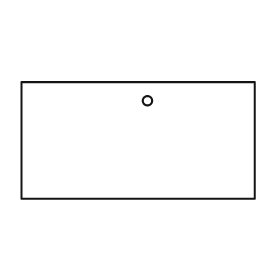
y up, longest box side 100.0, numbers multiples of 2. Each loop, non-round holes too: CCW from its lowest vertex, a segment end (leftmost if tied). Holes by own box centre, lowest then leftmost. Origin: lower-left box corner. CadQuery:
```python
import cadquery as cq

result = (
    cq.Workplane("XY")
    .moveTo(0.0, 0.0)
    .lineTo(100.0, 0.0)
    .lineTo(100.0, 50.0)
    .lineTo(0.0, 50.0)
    .close()
    .moveTo(54.0, 42.0)
    .circle(2.0)
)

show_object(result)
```